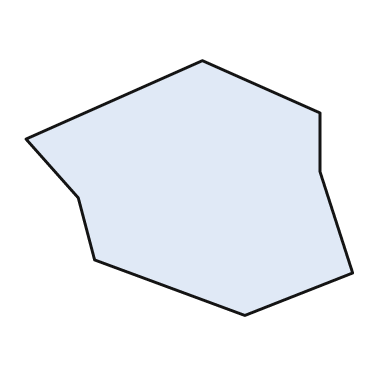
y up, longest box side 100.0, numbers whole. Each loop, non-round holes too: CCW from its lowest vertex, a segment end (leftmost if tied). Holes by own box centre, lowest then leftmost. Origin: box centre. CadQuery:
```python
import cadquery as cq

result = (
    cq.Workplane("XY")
    .moveTo(17.0, -39.0)
    .lineTo(50.0, -26.0)
    .lineTo(40.0, 5.0)
    .lineTo(40.0, 23.0)
    .lineTo(4.0, 39.0)
    .lineTo(-50.0, 15.0)
    .lineTo(-34.0, -3.0)
    .lineTo(-29.0, -22.0)
    .close()
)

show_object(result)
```